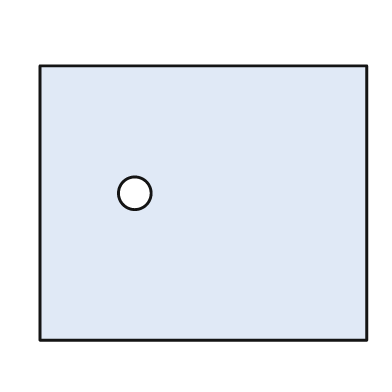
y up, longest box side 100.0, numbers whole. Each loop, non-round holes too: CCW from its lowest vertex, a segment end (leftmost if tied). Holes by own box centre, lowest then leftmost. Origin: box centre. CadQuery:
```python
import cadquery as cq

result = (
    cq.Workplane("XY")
    .moveTo(-50.0, -42.0)
    .lineTo(50.0, -42.0)
    .lineTo(50.0, 42.0)
    .lineTo(-50.0, 42.0)
    .close()
    .moveTo(-21.0, 3.0)
    .circle(5.0)
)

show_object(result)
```